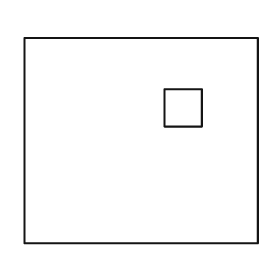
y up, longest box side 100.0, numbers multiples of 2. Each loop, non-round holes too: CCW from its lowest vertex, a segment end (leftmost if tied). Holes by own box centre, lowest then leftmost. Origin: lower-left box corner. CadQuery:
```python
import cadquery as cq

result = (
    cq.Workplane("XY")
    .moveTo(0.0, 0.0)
    .lineTo(100.0, 0.0)
    .lineTo(100.0, 88.0)
    .lineTo(0.0, 88.0)
    .close()
    .moveTo(60.0, 50.0)
    .lineTo(76.0, 50.0)
    .lineTo(76.0, 66.0)
    .lineTo(60.0, 66.0)
    .close()
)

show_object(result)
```